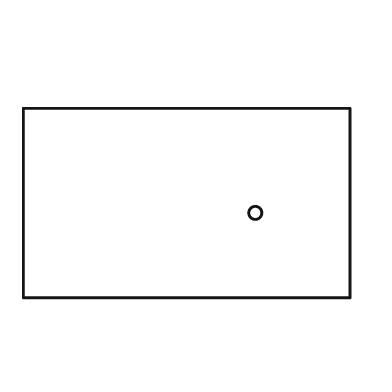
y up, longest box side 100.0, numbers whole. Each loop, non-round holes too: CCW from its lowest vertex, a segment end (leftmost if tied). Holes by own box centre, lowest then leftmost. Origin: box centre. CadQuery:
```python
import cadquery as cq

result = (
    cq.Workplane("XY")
    .moveTo(-50.0, -29.0)
    .lineTo(50.0, -29.0)
    .lineTo(50.0, 29.0)
    .lineTo(-50.0, 29.0)
    .close()
    .moveTo(21.0, -3.0)
    .circle(2.0)
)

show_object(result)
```